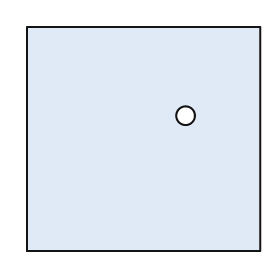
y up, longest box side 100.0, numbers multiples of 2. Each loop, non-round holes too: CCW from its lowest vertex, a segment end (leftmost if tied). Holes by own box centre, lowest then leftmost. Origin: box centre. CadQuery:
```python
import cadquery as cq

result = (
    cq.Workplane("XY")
    .moveTo(-50.0, -48.0)
    .lineTo(50.0, -48.0)
    .lineTo(50.0, 48.0)
    .lineTo(-50.0, 48.0)
    .close()
    .moveTo(18.0, 10.0)
    .circle(4.0)
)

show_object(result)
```